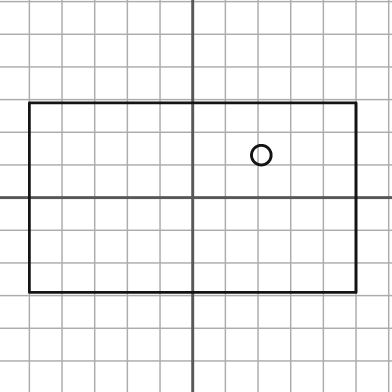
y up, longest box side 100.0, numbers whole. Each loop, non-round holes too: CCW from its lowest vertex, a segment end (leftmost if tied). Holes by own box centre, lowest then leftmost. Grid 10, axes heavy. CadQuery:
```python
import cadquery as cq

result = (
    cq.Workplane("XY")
    .moveTo(-50.0, -29.0)
    .lineTo(50.0, -29.0)
    .lineTo(50.0, 29.0)
    .lineTo(-50.0, 29.0)
    .close()
    .moveTo(21.0, 13.0)
    .circle(3.0)
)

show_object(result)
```